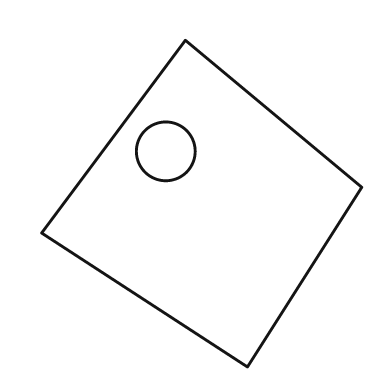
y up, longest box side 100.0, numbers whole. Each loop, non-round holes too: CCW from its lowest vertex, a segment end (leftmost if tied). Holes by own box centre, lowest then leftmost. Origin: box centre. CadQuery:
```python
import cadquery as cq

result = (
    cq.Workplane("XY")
    .moveTo(14.0, -50.0)
    .lineTo(49.0, 5.0)
    .lineTo(-5.0, 50.0)
    .lineTo(-49.0, -9.0)
    .close()
    .moveTo(-11.0, 16.0)
    .circle(9.0)
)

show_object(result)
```